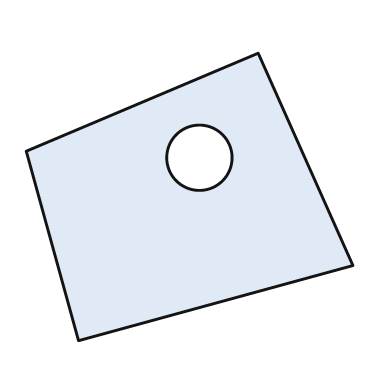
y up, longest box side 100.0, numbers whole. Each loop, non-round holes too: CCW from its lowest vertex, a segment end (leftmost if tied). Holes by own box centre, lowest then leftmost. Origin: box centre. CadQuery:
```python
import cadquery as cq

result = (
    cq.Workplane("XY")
    .moveTo(-34.0, -44.0)
    .lineTo(50.0, -21.0)
    .lineTo(21.0, 44.0)
    .lineTo(-50.0, 14.0)
    .close()
    .moveTo(3.0, 12.0)
    .circle(10.0)
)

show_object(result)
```